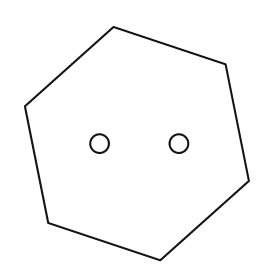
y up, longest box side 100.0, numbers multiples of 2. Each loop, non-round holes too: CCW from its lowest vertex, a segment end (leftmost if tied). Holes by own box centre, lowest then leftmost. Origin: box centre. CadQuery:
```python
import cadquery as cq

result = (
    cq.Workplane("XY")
    .moveTo(10.0, -50.0)
    .lineTo(48.0, -16.0)
    .lineTo(38.0, 34.0)
    .lineTo(-10.0, 50.0)
    .lineTo(-48.0, 16.0)
    .lineTo(-38.0, -34.0)
    .close()
    .moveTo(-16.0, 0.0)
    .circle(4.0)
    .moveTo(18.0, 0.0)
    .circle(4.0)
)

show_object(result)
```